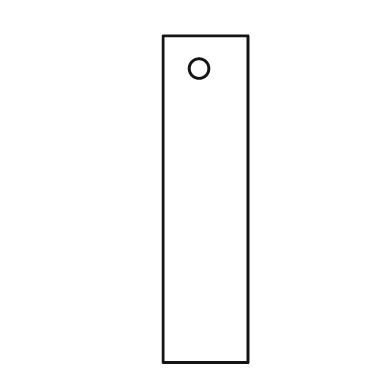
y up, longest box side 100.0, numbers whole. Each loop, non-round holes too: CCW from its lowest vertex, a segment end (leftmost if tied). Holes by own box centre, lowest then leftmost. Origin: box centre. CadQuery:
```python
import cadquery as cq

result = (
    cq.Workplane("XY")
    .moveTo(-13.0, -50.0)
    .lineTo(13.0, -50.0)
    .lineTo(13.0, 50.0)
    .lineTo(-13.0, 50.0)
    .close()
    .moveTo(-2.0, 40.0)
    .circle(3.0)
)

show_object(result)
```